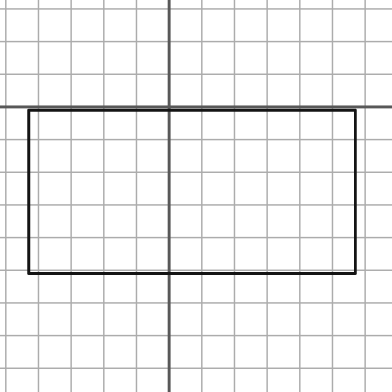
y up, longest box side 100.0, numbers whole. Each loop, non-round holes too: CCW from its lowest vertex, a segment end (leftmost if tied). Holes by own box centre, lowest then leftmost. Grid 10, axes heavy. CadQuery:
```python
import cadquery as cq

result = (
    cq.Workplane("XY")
    .moveTo(-43.0, -51.0)
    .lineTo(57.0, -51.0)
    .lineTo(57.0, -1.0)
    .lineTo(-43.0, -1.0)
    .close()
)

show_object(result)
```